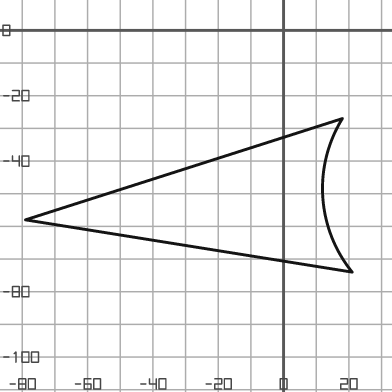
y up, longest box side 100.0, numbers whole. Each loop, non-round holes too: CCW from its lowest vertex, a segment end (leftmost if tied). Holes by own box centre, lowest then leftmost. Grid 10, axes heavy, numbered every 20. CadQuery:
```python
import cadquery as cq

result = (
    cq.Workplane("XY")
    .moveTo(21.0, -74.0)
    .threePointArc((12.0, -51.0), (18.0, -27.0))
    .lineTo(-79.0, -58.0)
    .close()
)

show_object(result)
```